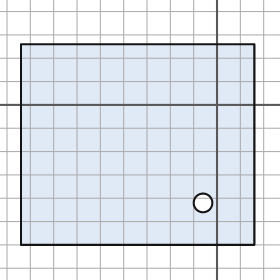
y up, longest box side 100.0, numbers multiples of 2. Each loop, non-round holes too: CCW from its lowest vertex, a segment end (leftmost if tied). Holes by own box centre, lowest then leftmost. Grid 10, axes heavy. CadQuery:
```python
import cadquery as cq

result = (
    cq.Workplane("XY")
    .moveTo(-84.0, -60.0)
    .lineTo(16.0, -60.0)
    .lineTo(16.0, 26.0)
    .lineTo(-84.0, 26.0)
    .close()
    .moveTo(-6.0, -42.0)
    .circle(4.0)
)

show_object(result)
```